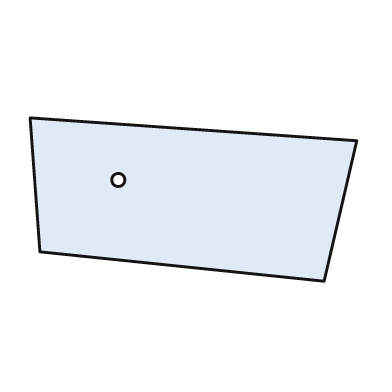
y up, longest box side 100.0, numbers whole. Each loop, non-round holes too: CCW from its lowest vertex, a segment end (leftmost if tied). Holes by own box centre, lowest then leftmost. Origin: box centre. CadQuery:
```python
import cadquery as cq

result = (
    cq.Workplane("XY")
    .moveTo(40.0, -25.0)
    .lineTo(50.0, 18.0)
    .lineTo(-50.0, 25.0)
    .lineTo(-47.0, -16.0)
    .close()
    .moveTo(-23.0, 6.0)
    .circle(2.0)
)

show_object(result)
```